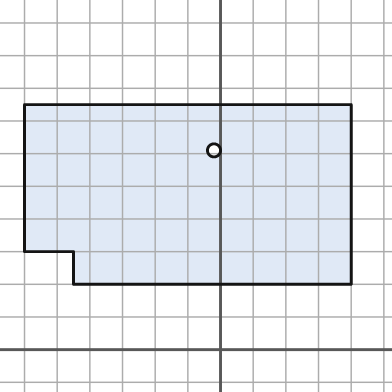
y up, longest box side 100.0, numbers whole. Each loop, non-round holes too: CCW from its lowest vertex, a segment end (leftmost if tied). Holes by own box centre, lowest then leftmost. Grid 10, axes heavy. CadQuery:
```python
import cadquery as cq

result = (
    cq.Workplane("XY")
    .moveTo(-45.0, 20.0)
    .lineTo(40.0, 20.0)
    .lineTo(40.0, 75.0)
    .lineTo(-60.0, 75.0)
    .lineTo(-60.0, 30.0)
    .lineTo(-45.0, 30.0)
    .close()
    .moveTo(-2.0, 61.0)
    .circle(2.0)
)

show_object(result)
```